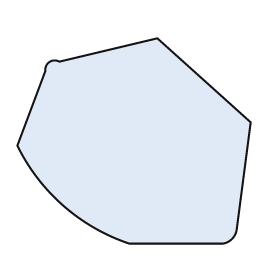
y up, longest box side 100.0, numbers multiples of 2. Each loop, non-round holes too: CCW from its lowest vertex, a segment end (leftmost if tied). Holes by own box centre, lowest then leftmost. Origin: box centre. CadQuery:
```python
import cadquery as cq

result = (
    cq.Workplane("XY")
    .moveTo(-2.0, -44.0)
    .lineTo(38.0, -44.0)
    .threePointArc((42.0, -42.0), (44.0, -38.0))
    .lineTo(50.0, 8.0)
    .lineTo(10.0, 44.0)
    .lineTo(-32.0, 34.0)
    .threePointArc((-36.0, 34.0), (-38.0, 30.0))
    .lineTo(-50.0, -2.0)
    .threePointArc((-30.0, -28.0), (-2.0, -44.0))
    .close()
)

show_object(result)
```